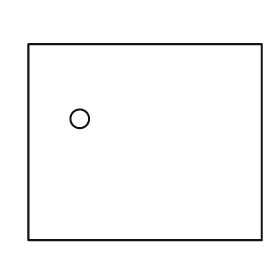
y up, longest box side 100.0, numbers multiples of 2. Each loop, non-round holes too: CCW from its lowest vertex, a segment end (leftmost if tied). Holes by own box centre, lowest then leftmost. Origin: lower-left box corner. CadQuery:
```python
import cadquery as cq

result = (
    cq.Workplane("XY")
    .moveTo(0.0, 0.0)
    .lineTo(100.0, 0.0)
    .lineTo(100.0, 84.0)
    .lineTo(0.0, 84.0)
    .close()
    .moveTo(22.0, 52.0)
    .circle(4.0)
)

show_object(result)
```